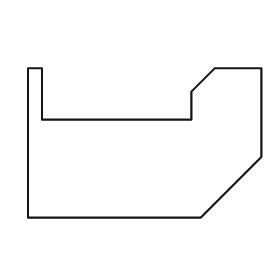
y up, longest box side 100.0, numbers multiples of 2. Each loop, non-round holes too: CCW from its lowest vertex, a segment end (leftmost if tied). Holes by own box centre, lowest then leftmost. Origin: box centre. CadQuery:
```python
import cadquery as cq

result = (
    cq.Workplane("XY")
    .moveTo(-50.0, -32.0)
    .lineTo(24.0, -32.0)
    .lineTo(50.0, -6.0)
    .lineTo(50.0, 32.0)
    .lineTo(30.0, 32.0)
    .lineTo(20.0, 22.0)
    .lineTo(20.0, 10.0)
    .lineTo(-44.0, 10.0)
    .lineTo(-44.0, 32.0)
    .lineTo(-50.0, 32.0)
    .close()
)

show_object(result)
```